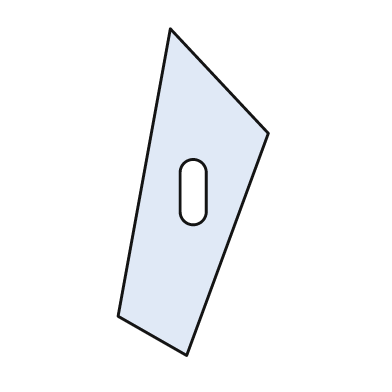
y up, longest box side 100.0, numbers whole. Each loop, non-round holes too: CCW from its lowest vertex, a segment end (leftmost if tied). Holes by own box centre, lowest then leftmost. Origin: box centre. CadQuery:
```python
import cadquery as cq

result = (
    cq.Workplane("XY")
    .moveTo(-2.0, -50.0)
    .lineTo(23.0, 18.0)
    .lineTo(-7.0, 50.0)
    .lineTo(-23.0, -38.0)
    .close()
    .moveTo(-4.0, -6.0)
    .threePointArc((0.0, -10.0), (4.0, -6.0))
    .lineTo(4.0, 6.0)
    .threePointArc((0.0, 10.0), (-4.0, 6.0))
    .close()
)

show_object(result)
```